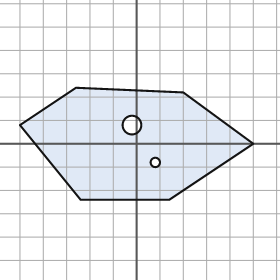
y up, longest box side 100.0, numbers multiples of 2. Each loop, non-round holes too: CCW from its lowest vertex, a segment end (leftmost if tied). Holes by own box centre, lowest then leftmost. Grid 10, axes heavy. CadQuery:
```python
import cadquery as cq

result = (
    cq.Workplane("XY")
    .moveTo(-24.0, -24.0)
    .lineTo(14.0, -24.0)
    .lineTo(50.0, 0.0)
    .lineTo(20.0, 22.0)
    .lineTo(-26.0, 24.0)
    .lineTo(-50.0, 8.0)
    .close()
    .moveTo(8.0, -8.0)
    .circle(2.0)
    .moveTo(-2.0, 8.0)
    .circle(4.0)
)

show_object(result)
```